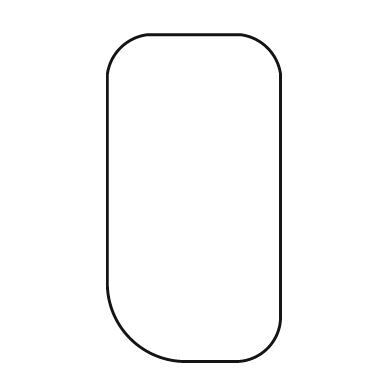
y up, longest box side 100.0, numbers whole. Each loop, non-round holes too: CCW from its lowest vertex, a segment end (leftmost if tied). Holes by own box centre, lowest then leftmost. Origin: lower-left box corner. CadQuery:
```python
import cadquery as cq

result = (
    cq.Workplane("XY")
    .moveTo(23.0, 0.0)
    .lineTo(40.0, 0.0)
    .threePointArc((49.0, 4.0), (53.0, 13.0))
    .lineTo(53.0, 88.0)
    .threePointArc((49.0, 96.0), (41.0, 100.0))
    .lineTo(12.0, 100.0)
    .threePointArc((4.0, 96.0), (0.0, 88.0))
    .lineTo(0.0, 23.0)
    .threePointArc((7.0, 7.0), (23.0, 0.0))
    .close()
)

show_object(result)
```